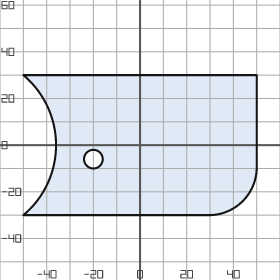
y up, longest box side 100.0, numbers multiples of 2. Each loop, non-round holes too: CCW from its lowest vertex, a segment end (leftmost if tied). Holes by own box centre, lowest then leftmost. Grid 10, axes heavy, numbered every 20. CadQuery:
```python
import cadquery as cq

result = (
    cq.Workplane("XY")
    .moveTo(-50.0, -30.0)
    .lineTo(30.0, -30.0)
    .threePointArc((44.0, -24.0), (50.0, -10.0))
    .lineTo(50.0, 30.0)
    .lineTo(-50.0, 30.0)
    .threePointArc((-36.0, 0.0), (-50.0, -30.0))
    .close()
    .moveTo(-20.0, -6.0)
    .circle(4.0)
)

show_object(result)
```